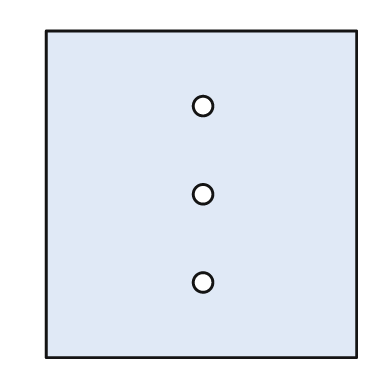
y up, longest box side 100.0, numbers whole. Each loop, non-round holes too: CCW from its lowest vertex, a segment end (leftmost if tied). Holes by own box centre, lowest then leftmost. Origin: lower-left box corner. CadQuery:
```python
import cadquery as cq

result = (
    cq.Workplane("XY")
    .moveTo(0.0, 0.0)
    .lineTo(95.0, 0.0)
    .lineTo(95.0, 100.0)
    .lineTo(0.0, 100.0)
    .close()
    .moveTo(48.0, 23.0)
    .circle(3.0)
    .moveTo(48.0, 50.0)
    .circle(3.0)
    .moveTo(48.0, 77.0)
    .circle(3.0)
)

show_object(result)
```